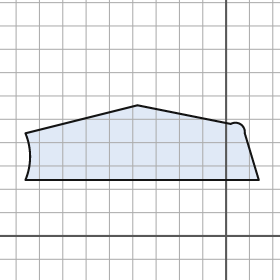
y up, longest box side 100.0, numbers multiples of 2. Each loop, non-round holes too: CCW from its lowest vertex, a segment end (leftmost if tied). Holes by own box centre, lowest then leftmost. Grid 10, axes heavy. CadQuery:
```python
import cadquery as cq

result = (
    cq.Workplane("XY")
    .moveTo(-86.0, 24.0)
    .lineTo(14.0, 24.0)
    .lineTo(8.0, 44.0)
    .threePointArc((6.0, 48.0), (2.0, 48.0))
    .lineTo(-38.0, 56.0)
    .lineTo(-86.0, 44.0)
    .threePointArc((-84.0, 34.0), (-86.0, 24.0))
    .close()
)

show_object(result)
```